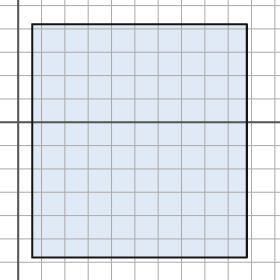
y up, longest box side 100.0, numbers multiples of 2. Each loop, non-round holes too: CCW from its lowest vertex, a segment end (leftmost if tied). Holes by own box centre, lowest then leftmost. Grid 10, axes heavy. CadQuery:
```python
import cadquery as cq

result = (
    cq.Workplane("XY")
    .moveTo(6.0, -58.0)
    .lineTo(98.0, -58.0)
    .lineTo(98.0, 42.0)
    .lineTo(6.0, 42.0)
    .close()
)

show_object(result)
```